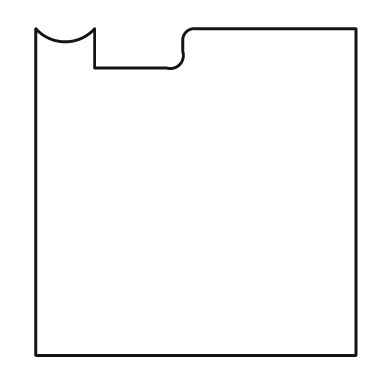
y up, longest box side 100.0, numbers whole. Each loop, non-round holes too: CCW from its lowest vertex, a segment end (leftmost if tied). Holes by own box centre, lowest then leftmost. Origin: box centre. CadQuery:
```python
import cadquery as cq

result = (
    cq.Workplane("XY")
    .moveTo(-49.0, -50.0)
    .lineTo(49.0, -50.0)
    .lineTo(49.0, 50.0)
    .lineTo(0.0, 50.0)
    .threePointArc((-3.0, 49.0), (-4.0, 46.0))
    .lineTo(-4.0, 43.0)
    .threePointArc((-5.0, 39.0), (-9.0, 38.0))
    .lineTo(-31.0, 38.0)
    .lineTo(-31.0, 50.0)
    .threePointArc((-40.0, 46.0), (-49.0, 50.0))
    .close()
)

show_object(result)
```